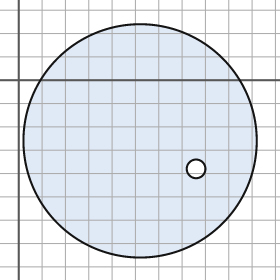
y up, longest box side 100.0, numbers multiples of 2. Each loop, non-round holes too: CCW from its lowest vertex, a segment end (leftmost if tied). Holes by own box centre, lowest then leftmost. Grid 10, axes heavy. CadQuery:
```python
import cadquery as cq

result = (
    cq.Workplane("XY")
    .moveTo(52.0, -26.0)
    .circle(50.0)
    .moveTo(76.0, -38.0)
    .circle(4.0)
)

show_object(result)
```